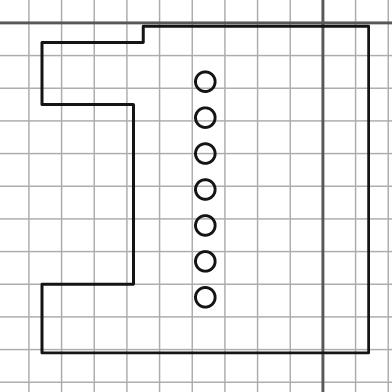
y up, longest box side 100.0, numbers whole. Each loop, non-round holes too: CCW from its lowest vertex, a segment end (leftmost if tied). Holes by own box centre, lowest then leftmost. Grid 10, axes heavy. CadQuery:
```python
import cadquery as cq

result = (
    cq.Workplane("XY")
    .moveTo(-86.0, -101.0)
    .lineTo(14.0, -101.0)
    .lineTo(14.0, -1.0)
    .lineTo(-55.0, -1.0)
    .lineTo(-55.0, -6.0)
    .lineTo(-86.0, -6.0)
    .lineTo(-86.0, -25.0)
    .lineTo(-58.0, -25.0)
    .lineTo(-58.0, -80.0)
    .lineTo(-86.0, -80.0)
    .close()
    .moveTo(-36.0, -84.0)
    .circle(3.0)
    .moveTo(-36.0, -73.0)
    .circle(3.0)
    .moveTo(-36.0, -62.0)
    .circle(3.0)
    .moveTo(-36.0, -51.0)
    .circle(3.0)
    .moveTo(-36.0, -40.0)
    .circle(3.0)
    .moveTo(-36.0, -29.0)
    .circle(3.0)
    .moveTo(-36.0, -18.0)
    .circle(3.0)
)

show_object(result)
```